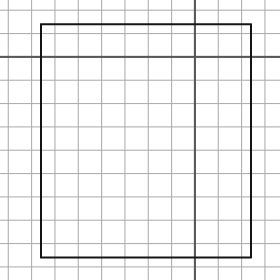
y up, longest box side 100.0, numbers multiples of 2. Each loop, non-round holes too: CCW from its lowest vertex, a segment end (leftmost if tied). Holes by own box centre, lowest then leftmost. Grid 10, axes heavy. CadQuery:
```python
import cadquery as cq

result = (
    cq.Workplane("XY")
    .moveTo(-66.0, -86.0)
    .lineTo(24.0, -86.0)
    .lineTo(24.0, 14.0)
    .lineTo(-66.0, 14.0)
    .close()
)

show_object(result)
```